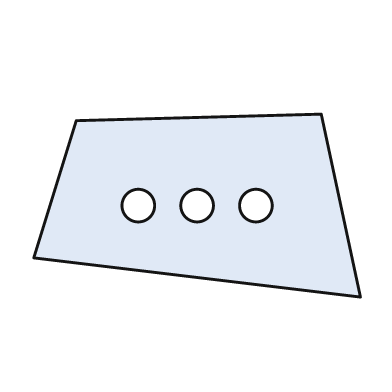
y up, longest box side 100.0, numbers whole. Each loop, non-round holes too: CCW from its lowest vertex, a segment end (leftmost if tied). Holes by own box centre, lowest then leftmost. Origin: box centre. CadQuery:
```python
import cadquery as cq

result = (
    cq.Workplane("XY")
    .moveTo(50.0, -28.0)
    .lineTo(38.0, 28.0)
    .lineTo(-37.0, 26.0)
    .lineTo(-50.0, -16.0)
    .close()
    .moveTo(-18.0, 0.0)
    .circle(5.0)
    .moveTo(0.0, 0.0)
    .circle(5.0)
    .moveTo(18.0, 0.0)
    .circle(5.0)
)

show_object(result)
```